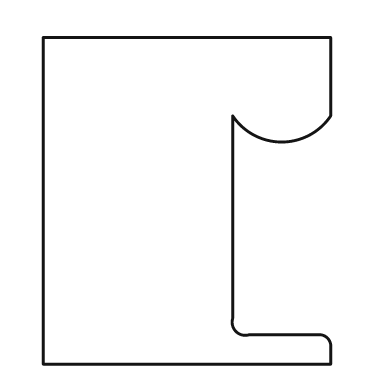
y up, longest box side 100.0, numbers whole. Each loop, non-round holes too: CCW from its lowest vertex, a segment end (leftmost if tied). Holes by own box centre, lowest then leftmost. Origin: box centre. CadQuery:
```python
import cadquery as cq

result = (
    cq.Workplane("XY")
    .moveTo(-44.0, -50.0)
    .lineTo(44.0, -50.0)
    .lineTo(44.0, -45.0)
    .threePointArc((43.0, -42.0), (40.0, -41.0))
    .lineTo(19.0, -41.0)
    .threePointArc((15.0, -40.0), (14.0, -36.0))
    .lineTo(14.0, 26.0)
    .threePointArc((29.0, 18.0), (44.0, 26.0))
    .lineTo(44.0, 50.0)
    .lineTo(-44.0, 50.0)
    .close()
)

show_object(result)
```